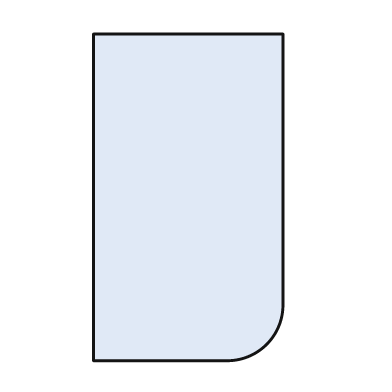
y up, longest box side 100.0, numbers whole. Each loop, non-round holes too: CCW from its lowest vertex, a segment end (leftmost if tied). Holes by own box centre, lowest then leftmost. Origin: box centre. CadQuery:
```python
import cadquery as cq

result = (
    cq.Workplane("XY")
    .moveTo(-29.0, -50.0)
    .lineTo(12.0, -50.0)
    .threePointArc((24.0, -45.0), (29.0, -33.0))
    .lineTo(29.0, 50.0)
    .lineTo(-29.0, 50.0)
    .close()
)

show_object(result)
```